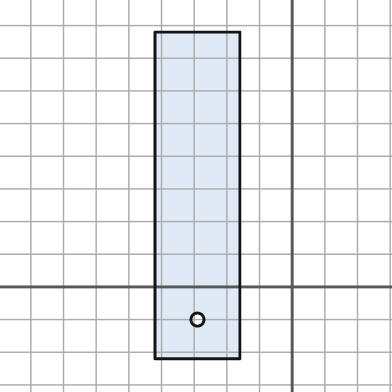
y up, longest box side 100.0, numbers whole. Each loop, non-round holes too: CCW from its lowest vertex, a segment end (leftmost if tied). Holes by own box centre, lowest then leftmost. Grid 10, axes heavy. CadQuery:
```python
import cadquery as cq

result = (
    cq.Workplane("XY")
    .moveTo(-42.0, -22.0)
    .lineTo(-16.0, -22.0)
    .lineTo(-16.0, 78.0)
    .lineTo(-42.0, 78.0)
    .close()
    .moveTo(-29.0, -10.0)
    .circle(2.0)
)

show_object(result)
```